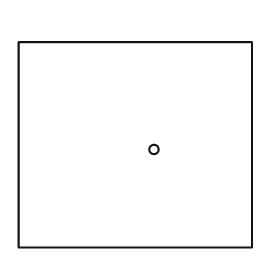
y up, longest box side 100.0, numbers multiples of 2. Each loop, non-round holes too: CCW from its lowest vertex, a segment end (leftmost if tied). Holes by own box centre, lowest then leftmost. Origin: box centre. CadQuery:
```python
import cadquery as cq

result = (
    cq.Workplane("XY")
    .moveTo(-50.0, -44.0)
    .lineTo(50.0, -44.0)
    .lineTo(50.0, 44.0)
    .lineTo(-50.0, 44.0)
    .close()
    .moveTo(8.0, -2.0)
    .circle(2.0)
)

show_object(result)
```